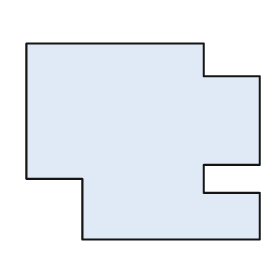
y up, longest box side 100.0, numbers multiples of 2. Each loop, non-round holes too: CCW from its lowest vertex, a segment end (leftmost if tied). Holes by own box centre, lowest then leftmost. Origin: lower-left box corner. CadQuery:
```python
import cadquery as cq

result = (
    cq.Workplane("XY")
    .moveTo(24.0, 0.0)
    .lineTo(100.0, 0.0)
    .lineTo(100.0, 20.0)
    .lineTo(76.0, 20.0)
    .lineTo(76.0, 32.0)
    .lineTo(100.0, 32.0)
    .lineTo(100.0, 70.0)
    .lineTo(76.0, 70.0)
    .lineTo(76.0, 84.0)
    .lineTo(0.0, 84.0)
    .lineTo(0.0, 26.0)
    .lineTo(24.0, 26.0)
    .close()
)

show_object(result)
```